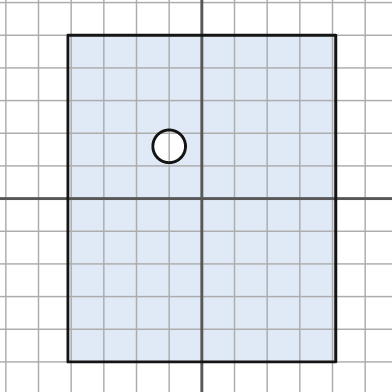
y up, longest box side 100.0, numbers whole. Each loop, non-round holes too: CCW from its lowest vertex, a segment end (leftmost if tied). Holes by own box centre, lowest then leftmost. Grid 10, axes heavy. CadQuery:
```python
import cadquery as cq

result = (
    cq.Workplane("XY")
    .moveTo(-41.0, -50.0)
    .lineTo(41.0, -50.0)
    .lineTo(41.0, 50.0)
    .lineTo(-41.0, 50.0)
    .close()
    .moveTo(-10.0, 16.0)
    .circle(5.0)
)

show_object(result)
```